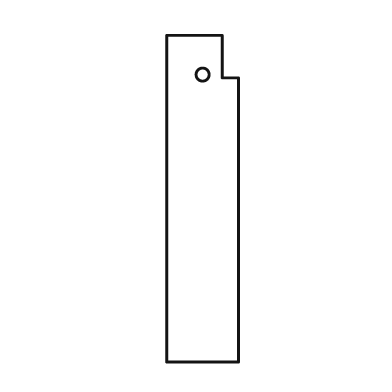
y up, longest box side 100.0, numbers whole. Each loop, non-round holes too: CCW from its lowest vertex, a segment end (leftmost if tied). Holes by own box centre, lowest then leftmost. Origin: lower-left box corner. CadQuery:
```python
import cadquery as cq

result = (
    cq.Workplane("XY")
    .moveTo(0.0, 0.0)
    .lineTo(22.0, 0.0)
    .lineTo(22.0, 87.0)
    .lineTo(17.0, 87.0)
    .lineTo(17.0, 100.0)
    .lineTo(0.0, 100.0)
    .close()
    .moveTo(11.0, 88.0)
    .circle(2.0)
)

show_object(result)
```